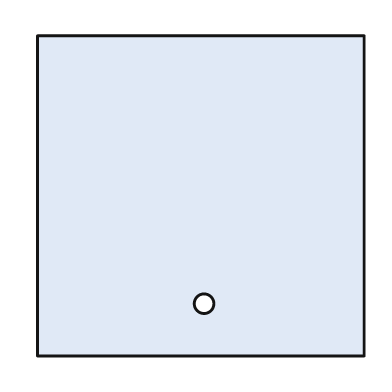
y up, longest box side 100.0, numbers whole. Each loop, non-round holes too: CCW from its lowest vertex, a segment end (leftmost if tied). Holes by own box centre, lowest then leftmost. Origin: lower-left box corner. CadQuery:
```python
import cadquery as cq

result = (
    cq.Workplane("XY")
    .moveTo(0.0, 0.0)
    .lineTo(100.0, 0.0)
    .lineTo(100.0, 98.0)
    .lineTo(0.0, 98.0)
    .close()
    .moveTo(51.0, 16.0)
    .circle(3.0)
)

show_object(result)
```